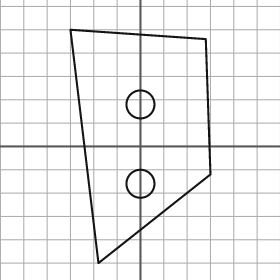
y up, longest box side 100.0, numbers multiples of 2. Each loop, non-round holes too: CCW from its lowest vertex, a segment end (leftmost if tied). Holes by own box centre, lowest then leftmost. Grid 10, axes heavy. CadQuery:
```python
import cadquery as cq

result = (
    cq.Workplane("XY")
    .moveTo(-18.0, -50.0)
    .lineTo(30.0, -12.0)
    .lineTo(28.0, 46.0)
    .lineTo(-30.0, 50.0)
    .close()
    .moveTo(0.0, -16.0)
    .circle(6.0)
    .moveTo(0.0, 18.0)
    .circle(6.0)
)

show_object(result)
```